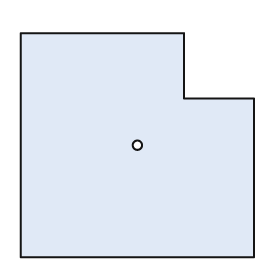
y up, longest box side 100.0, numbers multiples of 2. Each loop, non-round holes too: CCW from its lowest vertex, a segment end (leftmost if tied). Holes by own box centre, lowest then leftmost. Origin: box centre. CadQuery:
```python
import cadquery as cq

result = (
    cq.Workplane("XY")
    .moveTo(-50.0, -48.0)
    .lineTo(50.0, -48.0)
    .lineTo(50.0, 20.0)
    .lineTo(20.0, 20.0)
    .lineTo(20.0, 48.0)
    .lineTo(-50.0, 48.0)
    .close()
    .moveTo(0.0, 0.0)
    .circle(2.0)
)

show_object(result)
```